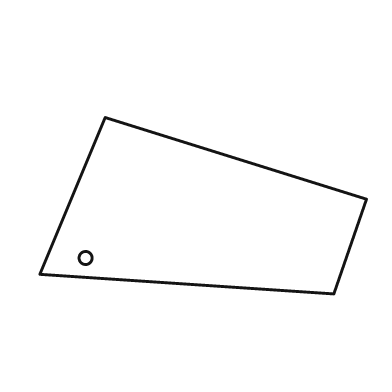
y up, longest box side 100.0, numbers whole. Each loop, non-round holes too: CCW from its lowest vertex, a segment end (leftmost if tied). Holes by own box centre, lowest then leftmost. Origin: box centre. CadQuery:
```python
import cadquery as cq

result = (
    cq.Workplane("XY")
    .moveTo(40.0, -27.0)
    .lineTo(50.0, 2.0)
    .lineTo(-30.0, 27.0)
    .lineTo(-50.0, -21.0)
    .close()
    .moveTo(-36.0, -16.0)
    .circle(2.0)
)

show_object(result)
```